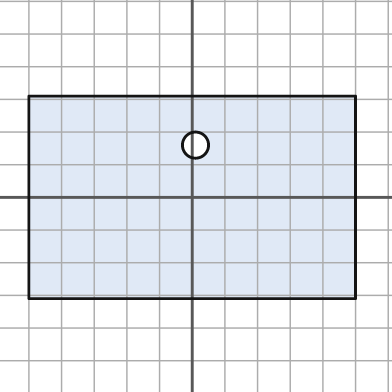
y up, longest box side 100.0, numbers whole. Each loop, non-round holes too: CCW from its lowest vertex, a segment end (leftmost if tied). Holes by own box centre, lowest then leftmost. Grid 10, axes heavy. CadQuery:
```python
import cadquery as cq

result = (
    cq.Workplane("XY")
    .moveTo(-50.0, -31.0)
    .lineTo(50.0, -31.0)
    .lineTo(50.0, 31.0)
    .lineTo(-50.0, 31.0)
    .close()
    .moveTo(1.0, 16.0)
    .circle(4.0)
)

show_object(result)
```